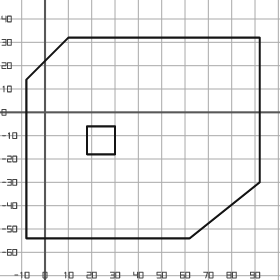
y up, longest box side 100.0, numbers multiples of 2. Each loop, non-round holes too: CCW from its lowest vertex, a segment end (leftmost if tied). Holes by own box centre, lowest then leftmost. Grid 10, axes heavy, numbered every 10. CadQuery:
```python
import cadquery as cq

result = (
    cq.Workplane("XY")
    .moveTo(-8.0, -54.0)
    .lineTo(62.0, -54.0)
    .lineTo(92.0, -30.0)
    .lineTo(92.0, 32.0)
    .lineTo(10.0, 32.0)
    .lineTo(-8.0, 14.0)
    .close()
    .moveTo(18.0, -18.0)
    .lineTo(30.0, -18.0)
    .lineTo(30.0, -6.0)
    .lineTo(18.0, -6.0)
    .close()
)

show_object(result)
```